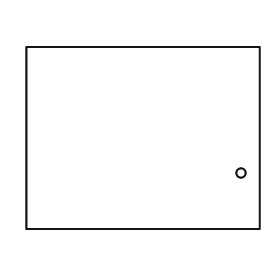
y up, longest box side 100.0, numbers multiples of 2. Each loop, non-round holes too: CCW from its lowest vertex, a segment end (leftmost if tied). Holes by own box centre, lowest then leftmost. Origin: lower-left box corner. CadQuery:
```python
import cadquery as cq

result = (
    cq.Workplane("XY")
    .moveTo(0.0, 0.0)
    .lineTo(100.0, 0.0)
    .lineTo(100.0, 78.0)
    .lineTo(0.0, 78.0)
    .close()
    .moveTo(92.0, 24.0)
    .circle(2.0)
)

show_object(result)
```